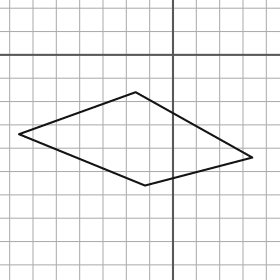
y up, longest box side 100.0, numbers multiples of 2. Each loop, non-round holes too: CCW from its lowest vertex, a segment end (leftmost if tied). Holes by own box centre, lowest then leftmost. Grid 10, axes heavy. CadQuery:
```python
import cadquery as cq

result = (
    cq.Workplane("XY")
    .moveTo(-12.0, -56.0)
    .lineTo(34.0, -44.0)
    .lineTo(-16.0, -16.0)
    .lineTo(-66.0, -34.0)
    .close()
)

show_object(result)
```